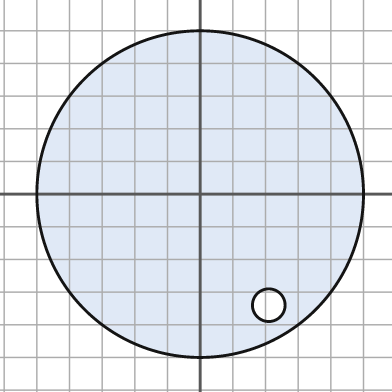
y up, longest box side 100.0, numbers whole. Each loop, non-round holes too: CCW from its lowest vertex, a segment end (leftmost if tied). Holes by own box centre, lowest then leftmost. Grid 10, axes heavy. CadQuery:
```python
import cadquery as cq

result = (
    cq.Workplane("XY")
    .moveTo(0.0, 0.0)
    .circle(50.0)
    .moveTo(21.0, -34.0)
    .circle(5.0)
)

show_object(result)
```